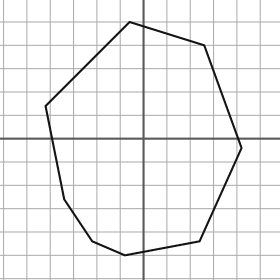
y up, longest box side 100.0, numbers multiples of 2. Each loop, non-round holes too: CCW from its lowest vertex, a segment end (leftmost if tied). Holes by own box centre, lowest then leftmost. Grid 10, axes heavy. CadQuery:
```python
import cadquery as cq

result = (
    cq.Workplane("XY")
    .moveTo(-8.0, -50.0)
    .lineTo(24.0, -44.0)
    .lineTo(42.0, -4.0)
    .lineTo(26.0, 40.0)
    .lineTo(-6.0, 50.0)
    .lineTo(-42.0, 14.0)
    .lineTo(-34.0, -26.0)
    .lineTo(-22.0, -44.0)
    .close()
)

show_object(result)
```